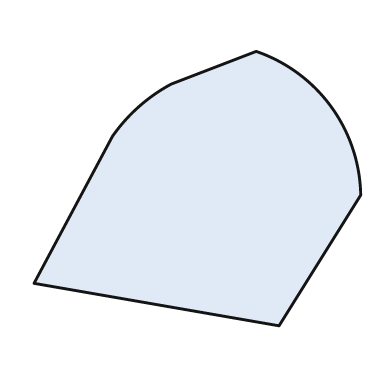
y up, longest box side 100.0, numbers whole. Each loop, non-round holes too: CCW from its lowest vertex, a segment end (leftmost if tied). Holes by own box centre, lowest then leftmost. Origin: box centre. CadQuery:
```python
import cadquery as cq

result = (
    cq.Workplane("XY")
    .moveTo(25.0, -42.0)
    .lineTo(50.0, -2.0)
    .threePointArc((41.0, 25.0), (18.0, 42.0))
    .lineTo(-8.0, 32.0)
    .threePointArc((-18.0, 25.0), (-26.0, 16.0))
    .lineTo(-50.0, -29.0)
    .close()
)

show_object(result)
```